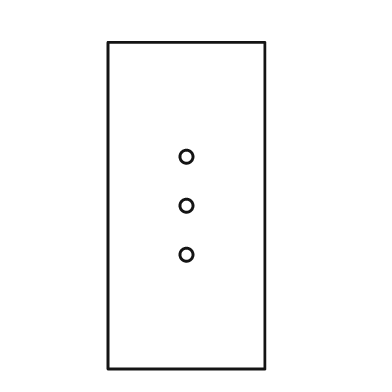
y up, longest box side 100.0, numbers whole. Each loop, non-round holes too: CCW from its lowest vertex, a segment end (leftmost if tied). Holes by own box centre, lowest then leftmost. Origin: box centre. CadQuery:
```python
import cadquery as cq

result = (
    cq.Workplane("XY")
    .moveTo(-24.0, -50.0)
    .lineTo(24.0, -50.0)
    .lineTo(24.0, 50.0)
    .lineTo(-24.0, 50.0)
    .close()
    .moveTo(0.0, -15.0)
    .circle(2.0)
    .moveTo(0.0, 0.0)
    .circle(2.0)
    .moveTo(0.0, 15.0)
    .circle(2.0)
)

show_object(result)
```